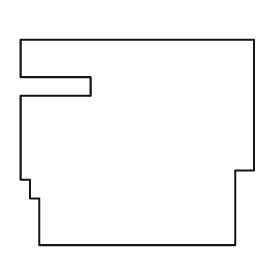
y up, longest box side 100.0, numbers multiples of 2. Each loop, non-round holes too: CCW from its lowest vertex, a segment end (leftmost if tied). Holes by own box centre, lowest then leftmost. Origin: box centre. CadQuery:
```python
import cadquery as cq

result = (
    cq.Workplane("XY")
    .moveTo(-42.0, -44.0)
    .lineTo(42.0, -44.0)
    .lineTo(42.0, -12.0)
    .lineTo(50.0, -12.0)
    .lineTo(50.0, 44.0)
    .lineTo(-50.0, 44.0)
    .lineTo(-50.0, 28.0)
    .lineTo(-20.0, 28.0)
    .lineTo(-20.0, 20.0)
    .lineTo(-50.0, 20.0)
    .lineTo(-50.0, -16.0)
    .lineTo(-46.0, -16.0)
    .lineTo(-46.0, -24.0)
    .lineTo(-42.0, -24.0)
    .close()
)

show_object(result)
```